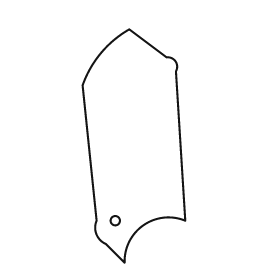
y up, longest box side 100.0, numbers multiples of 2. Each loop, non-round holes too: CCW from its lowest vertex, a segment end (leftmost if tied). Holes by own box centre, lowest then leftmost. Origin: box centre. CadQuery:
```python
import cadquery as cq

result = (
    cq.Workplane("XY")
    .moveTo(-4.0, -50.0)
    .threePointArc((4.0, -34.0), (22.0, -32.0))
    .lineTo(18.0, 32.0)
    .threePointArc((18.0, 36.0), (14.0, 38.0))
    .lineTo(-2.0, 50.0)
    .threePointArc((-14.0, 40.0), (-22.0, 26.0))
    .lineTo(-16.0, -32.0)
    .threePointArc((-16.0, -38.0), (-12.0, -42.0))
    .close()
    .moveTo(-8.0, -32.0)
    .circle(2.0)
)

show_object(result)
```